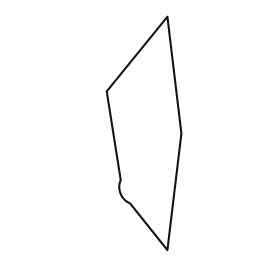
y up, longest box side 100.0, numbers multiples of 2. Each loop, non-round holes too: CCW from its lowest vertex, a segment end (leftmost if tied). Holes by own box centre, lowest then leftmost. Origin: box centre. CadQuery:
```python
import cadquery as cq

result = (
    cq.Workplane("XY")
    .moveTo(10.0, -50.0)
    .lineTo(16.0, 0.0)
    .lineTo(10.0, 50.0)
    .lineTo(-16.0, 18.0)
    .lineTo(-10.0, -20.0)
    .threePointArc((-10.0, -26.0), (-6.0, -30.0))
    .close()
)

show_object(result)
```